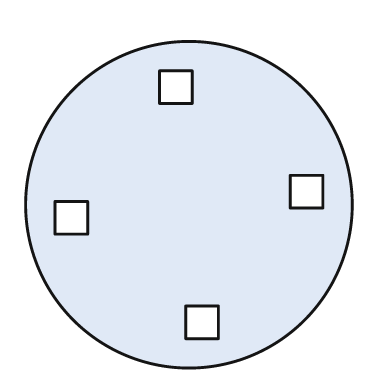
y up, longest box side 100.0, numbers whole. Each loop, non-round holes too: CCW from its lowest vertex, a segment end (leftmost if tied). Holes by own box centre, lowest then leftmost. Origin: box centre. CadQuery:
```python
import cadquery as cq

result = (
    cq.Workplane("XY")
    .moveTo(0.0, 0.0)
    .circle(50.0)
    .moveTo(-1.0, -41.0)
    .lineTo(9.0, -41.0)
    .lineTo(9.0, -31.0)
    .lineTo(-1.0, -31.0)
    .close()
    .moveTo(-41.0, -9.0)
    .lineTo(-31.0, -9.0)
    .lineTo(-31.0, 1.0)
    .lineTo(-41.0, 1.0)
    .close()
    .moveTo(31.0, -1.0)
    .lineTo(41.0, -1.0)
    .lineTo(41.0, 9.0)
    .lineTo(31.0, 9.0)
    .close()
    .moveTo(-9.0, 31.0)
    .lineTo(1.0, 31.0)
    .lineTo(1.0, 41.0)
    .lineTo(-9.0, 41.0)
    .close()
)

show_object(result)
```